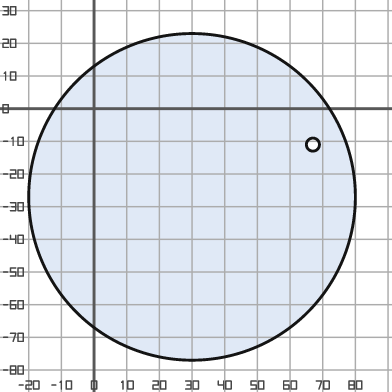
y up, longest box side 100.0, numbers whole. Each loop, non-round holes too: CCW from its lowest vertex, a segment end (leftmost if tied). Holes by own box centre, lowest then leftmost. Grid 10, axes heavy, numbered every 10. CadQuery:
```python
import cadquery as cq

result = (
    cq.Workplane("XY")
    .moveTo(30.0, -27.0)
    .circle(50.0)
    .moveTo(67.0, -11.0)
    .circle(2.0)
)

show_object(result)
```